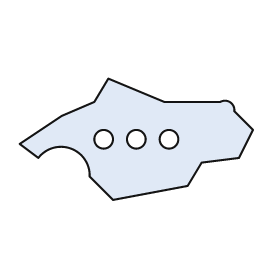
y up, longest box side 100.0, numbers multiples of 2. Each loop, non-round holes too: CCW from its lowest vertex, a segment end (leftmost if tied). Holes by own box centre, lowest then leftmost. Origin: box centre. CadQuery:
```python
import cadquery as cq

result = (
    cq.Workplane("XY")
    .moveTo(-10.0, -26.0)
    .lineTo(22.0, -20.0)
    .lineTo(28.0, -10.0)
    .lineTo(44.0, -8.0)
    .lineTo(50.0, 4.0)
    .lineTo(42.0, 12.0)
    .threePointArc((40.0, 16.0), (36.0, 16.0))
    .lineTo(12.0, 16.0)
    .lineTo(-12.0, 26.0)
    .lineTo(-18.0, 16.0)
    .lineTo(-32.0, 10.0)
    .lineTo(-50.0, -2.0)
    .lineTo(-42.0, -8.0)
    .threePointArc((-28.0, -4.0), (-20.0, -16.0))
    .close()
    .moveTo(-14.0, 0.0)
    .circle(4.0)
    .moveTo(0.0, 0.0)
    .circle(4.0)
    .moveTo(14.0, 0.0)
    .circle(4.0)
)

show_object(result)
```